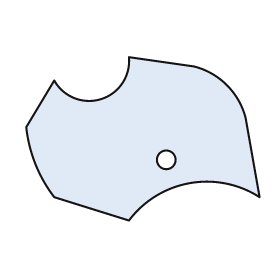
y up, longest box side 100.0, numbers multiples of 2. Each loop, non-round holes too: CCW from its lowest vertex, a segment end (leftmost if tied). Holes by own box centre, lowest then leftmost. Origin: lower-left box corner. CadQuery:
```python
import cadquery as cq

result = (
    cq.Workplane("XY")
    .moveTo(44.0, 0.0)
    .threePointArc((70.0, 16.0), (100.0, 10.0))
    .lineTo(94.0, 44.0)
    .threePointArc((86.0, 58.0), (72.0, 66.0))
    .lineTo(44.0, 70.0)
    .threePointArc((32.0, 52.0), (12.0, 60.0))
    .lineTo(0.0, 40.0)
    .threePointArc((4.0, 24.0), (12.0, 10.0))
    .close()
    .moveTo(60.0, 26.0)
    .circle(4.0)
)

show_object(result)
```